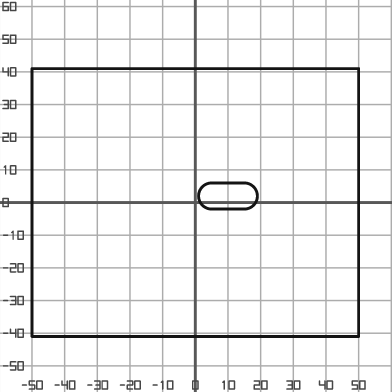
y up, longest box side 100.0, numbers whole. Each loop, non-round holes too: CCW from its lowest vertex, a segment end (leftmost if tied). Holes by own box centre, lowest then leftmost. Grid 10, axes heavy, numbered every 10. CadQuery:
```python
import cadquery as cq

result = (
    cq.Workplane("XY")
    .moveTo(-50.0, -41.0)
    .lineTo(50.0, -41.0)
    .lineTo(50.0, 41.0)
    .lineTo(-50.0, 41.0)
    .close()
    .moveTo(5.0, -2.0)
    .lineTo(15.0, -2.0)
    .threePointArc((19.0, 2.0), (15.0, 6.0))
    .lineTo(5.0, 6.0)
    .threePointArc((1.0, 2.0), (5.0, -2.0))
    .close()
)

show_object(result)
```